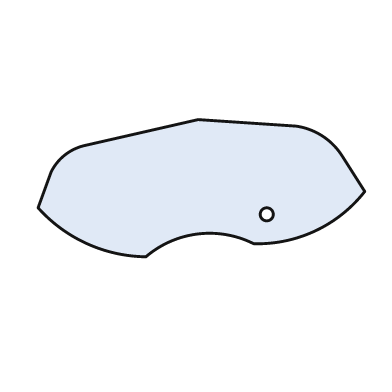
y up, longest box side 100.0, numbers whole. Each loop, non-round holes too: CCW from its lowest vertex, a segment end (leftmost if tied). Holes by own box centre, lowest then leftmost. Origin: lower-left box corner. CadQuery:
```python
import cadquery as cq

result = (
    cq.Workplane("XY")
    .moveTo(33.0, 0.0)
    .threePointArc((49.0, 7.0), (66.0, 4.0))
    .threePointArc((85.0, 8.0), (100.0, 20.0))
    .lineTo(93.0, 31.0)
    .threePointArc((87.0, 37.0), (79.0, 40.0))
    .lineTo(49.0, 42.0)
    .lineTo(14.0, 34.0)
    .threePointArc((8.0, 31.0), (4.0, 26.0))
    .lineTo(0.0, 15.0)
    .threePointArc((15.0, 4.0), (33.0, 0.0))
    .close()
    .moveTo(70.0, 13.0)
    .circle(2.0)
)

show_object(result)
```